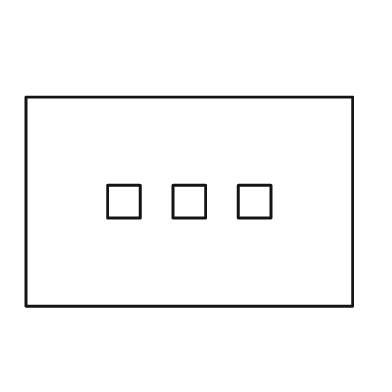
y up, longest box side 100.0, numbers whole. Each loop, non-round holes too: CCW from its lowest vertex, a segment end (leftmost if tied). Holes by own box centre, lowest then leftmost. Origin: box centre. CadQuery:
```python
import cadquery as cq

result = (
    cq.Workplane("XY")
    .moveTo(-50.0, -32.0)
    .lineTo(50.0, -32.0)
    .lineTo(50.0, 32.0)
    .lineTo(-50.0, 32.0)
    .close()
    .moveTo(-25.0, -5.0)
    .lineTo(-15.0, -5.0)
    .lineTo(-15.0, 5.0)
    .lineTo(-25.0, 5.0)
    .close()
    .moveTo(-5.0, -5.0)
    .lineTo(5.0, -5.0)
    .lineTo(5.0, 5.0)
    .lineTo(-5.0, 5.0)
    .close()
    .moveTo(15.0, -5.0)
    .lineTo(25.0, -5.0)
    .lineTo(25.0, 5.0)
    .lineTo(15.0, 5.0)
    .close()
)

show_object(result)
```